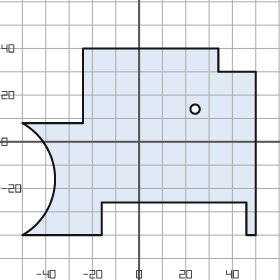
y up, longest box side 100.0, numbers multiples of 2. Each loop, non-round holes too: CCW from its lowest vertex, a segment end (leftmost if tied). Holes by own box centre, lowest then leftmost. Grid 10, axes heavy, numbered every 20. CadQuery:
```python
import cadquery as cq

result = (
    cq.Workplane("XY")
    .moveTo(-50.0, -40.0)
    .lineTo(-16.0, -40.0)
    .lineTo(-16.0, -26.0)
    .lineTo(46.0, -26.0)
    .lineTo(46.0, -40.0)
    .lineTo(50.0, -40.0)
    .lineTo(50.0, 30.0)
    .lineTo(34.0, 30.0)
    .lineTo(34.0, 40.0)
    .lineTo(-24.0, 40.0)
    .lineTo(-24.0, 8.0)
    .lineTo(-50.0, 8.0)
    .threePointArc((-36.0, -16.0), (-50.0, -40.0))
    .close()
    .moveTo(24.0, 14.0)
    .circle(2.0)
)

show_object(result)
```